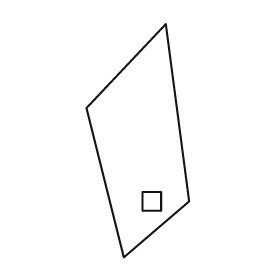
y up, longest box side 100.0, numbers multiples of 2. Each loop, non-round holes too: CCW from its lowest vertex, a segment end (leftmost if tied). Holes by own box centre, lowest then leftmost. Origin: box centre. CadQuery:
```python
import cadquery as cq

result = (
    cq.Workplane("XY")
    .moveTo(-6.0, -50.0)
    .lineTo(22.0, -26.0)
    .lineTo(12.0, 50.0)
    .lineTo(-22.0, 14.0)
    .close()
    .moveTo(2.0, -30.0)
    .lineTo(10.0, -30.0)
    .lineTo(10.0, -22.0)
    .lineTo(2.0, -22.0)
    .close()
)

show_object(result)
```